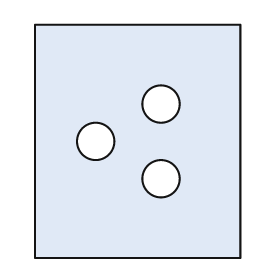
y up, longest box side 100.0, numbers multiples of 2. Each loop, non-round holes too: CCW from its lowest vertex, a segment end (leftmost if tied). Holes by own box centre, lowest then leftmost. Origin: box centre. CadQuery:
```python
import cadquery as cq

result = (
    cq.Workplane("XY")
    .moveTo(-44.0, -50.0)
    .lineTo(44.0, -50.0)
    .lineTo(44.0, 50.0)
    .lineTo(-44.0, 50.0)
    .close()
    .moveTo(10.0, -16.0)
    .circle(8.0)
    .moveTo(-18.0, 0.0)
    .circle(8.0)
    .moveTo(10.0, 16.0)
    .circle(8.0)
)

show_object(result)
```